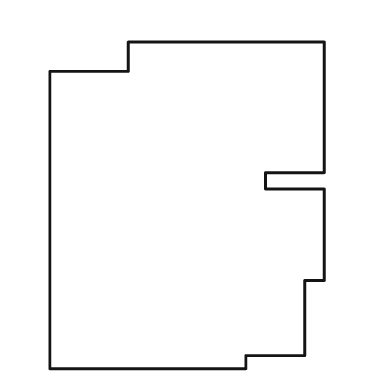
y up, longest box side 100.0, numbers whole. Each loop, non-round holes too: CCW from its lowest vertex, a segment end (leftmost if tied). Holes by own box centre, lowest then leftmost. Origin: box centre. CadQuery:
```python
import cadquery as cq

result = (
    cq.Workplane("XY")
    .moveTo(-42.0, -50.0)
    .lineTo(18.0, -50.0)
    .lineTo(18.0, -46.0)
    .lineTo(36.0, -46.0)
    .lineTo(36.0, -23.0)
    .lineTo(42.0, -23.0)
    .lineTo(42.0, 5.0)
    .lineTo(24.0, 5.0)
    .lineTo(24.0, 10.0)
    .lineTo(42.0, 10.0)
    .lineTo(42.0, 50.0)
    .lineTo(-18.0, 50.0)
    .lineTo(-18.0, 41.0)
    .lineTo(-42.0, 41.0)
    .close()
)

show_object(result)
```